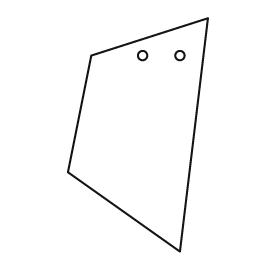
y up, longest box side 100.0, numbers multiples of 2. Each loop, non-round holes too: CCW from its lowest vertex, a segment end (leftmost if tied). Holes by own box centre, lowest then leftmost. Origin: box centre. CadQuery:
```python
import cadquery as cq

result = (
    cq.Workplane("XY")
    .moveTo(18.0, -50.0)
    .lineTo(30.0, 50.0)
    .lineTo(-20.0, 34.0)
    .lineTo(-30.0, -16.0)
    .close()
    .moveTo(2.0, 34.0)
    .circle(2.0)
    .moveTo(18.0, 34.0)
    .circle(2.0)
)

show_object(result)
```